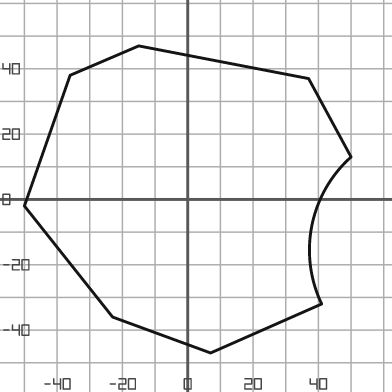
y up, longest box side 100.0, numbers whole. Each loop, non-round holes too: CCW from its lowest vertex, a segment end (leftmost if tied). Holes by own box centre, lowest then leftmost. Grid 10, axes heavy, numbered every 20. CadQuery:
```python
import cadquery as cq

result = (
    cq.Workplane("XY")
    .moveTo(7.0, -47.0)
    .lineTo(41.0, -32.0)
    .threePointArc((38.0, -8.0), (50.0, 13.0))
    .lineTo(37.0, 37.0)
    .lineTo(-15.0, 47.0)
    .lineTo(-36.0, 38.0)
    .lineTo(-50.0, -2.0)
    .lineTo(-23.0, -36.0)
    .close()
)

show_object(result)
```